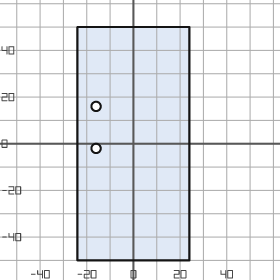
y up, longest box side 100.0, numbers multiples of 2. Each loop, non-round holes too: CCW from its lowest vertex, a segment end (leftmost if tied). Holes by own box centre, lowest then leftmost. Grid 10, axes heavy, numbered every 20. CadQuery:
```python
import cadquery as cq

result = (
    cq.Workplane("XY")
    .moveTo(-24.0, -50.0)
    .lineTo(24.0, -50.0)
    .lineTo(24.0, 50.0)
    .lineTo(-24.0, 50.0)
    .close()
    .moveTo(-16.0, -2.0)
    .circle(2.0)
    .moveTo(-16.0, 16.0)
    .circle(2.0)
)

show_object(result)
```